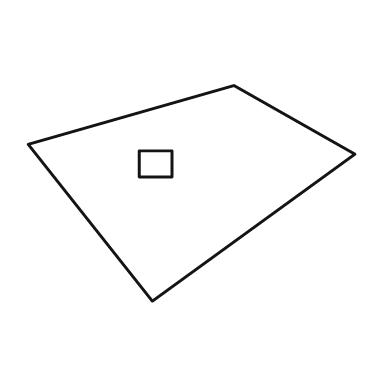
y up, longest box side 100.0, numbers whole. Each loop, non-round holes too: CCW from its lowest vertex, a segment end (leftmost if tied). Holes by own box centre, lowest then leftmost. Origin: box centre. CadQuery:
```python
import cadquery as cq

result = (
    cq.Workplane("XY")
    .moveTo(-12.0, -33.0)
    .lineTo(50.0, 12.0)
    .lineTo(13.0, 33.0)
    .lineTo(-50.0, 15.0)
    .close()
    .moveTo(-16.0, 5.0)
    .lineTo(-6.0, 5.0)
    .lineTo(-6.0, 13.0)
    .lineTo(-16.0, 13.0)
    .close()
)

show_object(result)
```